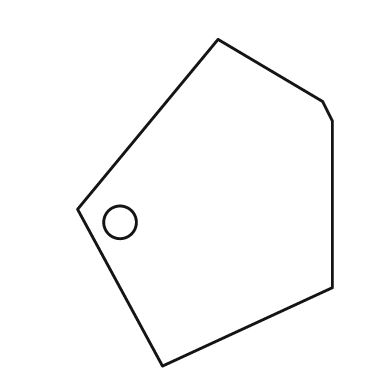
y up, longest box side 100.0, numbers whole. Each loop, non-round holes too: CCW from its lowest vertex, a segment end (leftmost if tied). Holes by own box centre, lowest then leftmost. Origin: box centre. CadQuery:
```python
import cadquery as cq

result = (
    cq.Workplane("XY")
    .moveTo(-13.0, -50.0)
    .lineTo(39.0, -26.0)
    .lineTo(39.0, 25.0)
    .lineTo(36.0, 31.0)
    .lineTo(4.0, 50.0)
    .lineTo(-39.0, -2.0)
    .close()
    .moveTo(-26.0, -6.0)
    .circle(5.0)
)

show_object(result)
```